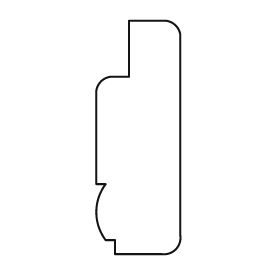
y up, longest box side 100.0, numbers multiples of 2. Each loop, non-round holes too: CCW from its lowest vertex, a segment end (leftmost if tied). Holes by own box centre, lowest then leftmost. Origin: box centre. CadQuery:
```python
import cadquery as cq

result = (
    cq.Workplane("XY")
    .moveTo(-10.0, -50.0)
    .lineTo(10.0, -50.0)
    .threePointArc((16.0, -48.0), (18.0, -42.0))
    .lineTo(18.0, 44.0)
    .threePointArc((16.0, 48.0), (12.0, 50.0))
    .lineTo(-4.0, 50.0)
    .lineTo(-4.0, 26.0)
    .lineTo(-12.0, 26.0)
    .threePointArc((-16.0, 24.0), (-18.0, 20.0))
    .lineTo(-18.0, -20.0)
    .lineTo(-14.0, -20.0)
    .threePointArc((-18.0, -32.0), (-14.0, -44.0))
    .lineTo(-10.0, -44.0)
    .close()
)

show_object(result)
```